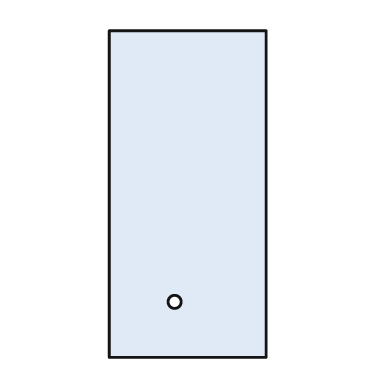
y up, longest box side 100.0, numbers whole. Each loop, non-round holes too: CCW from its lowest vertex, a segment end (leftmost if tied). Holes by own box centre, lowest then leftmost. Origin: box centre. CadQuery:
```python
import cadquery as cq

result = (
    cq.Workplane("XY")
    .moveTo(-24.0, -50.0)
    .lineTo(24.0, -50.0)
    .lineTo(24.0, 50.0)
    .lineTo(-24.0, 50.0)
    .close()
    .moveTo(-4.0, -33.0)
    .circle(2.0)
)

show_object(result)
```